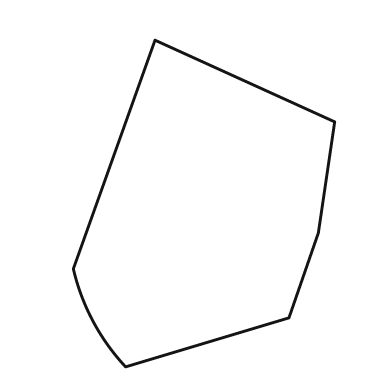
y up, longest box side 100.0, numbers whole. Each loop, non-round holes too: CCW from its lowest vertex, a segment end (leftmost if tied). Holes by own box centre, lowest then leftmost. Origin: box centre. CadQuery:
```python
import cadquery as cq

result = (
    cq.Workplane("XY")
    .moveTo(-24.0, -50.0)
    .lineTo(26.0, -35.0)
    .lineTo(35.0, -9.0)
    .lineTo(40.0, 25.0)
    .lineTo(-15.0, 50.0)
    .lineTo(-40.0, -20.0)
    .threePointArc((-34.0, -36.0), (-24.0, -50.0))
    .close()
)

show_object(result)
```